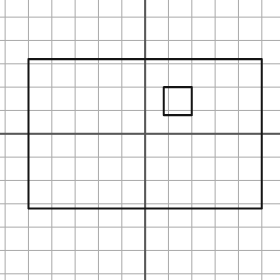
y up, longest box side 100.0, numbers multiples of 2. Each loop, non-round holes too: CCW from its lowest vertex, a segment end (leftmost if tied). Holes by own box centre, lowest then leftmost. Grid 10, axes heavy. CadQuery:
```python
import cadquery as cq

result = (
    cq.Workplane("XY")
    .moveTo(-50.0, -32.0)
    .lineTo(50.0, -32.0)
    .lineTo(50.0, 32.0)
    .lineTo(-50.0, 32.0)
    .close()
    .moveTo(8.0, 8.0)
    .lineTo(20.0, 8.0)
    .lineTo(20.0, 20.0)
    .lineTo(8.0, 20.0)
    .close()
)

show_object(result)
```